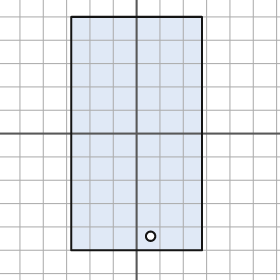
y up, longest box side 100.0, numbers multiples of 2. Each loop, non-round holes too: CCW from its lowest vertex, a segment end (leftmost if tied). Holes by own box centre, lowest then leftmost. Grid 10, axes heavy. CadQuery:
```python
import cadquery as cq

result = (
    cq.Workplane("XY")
    .moveTo(-28.0, -50.0)
    .lineTo(28.0, -50.0)
    .lineTo(28.0, 50.0)
    .lineTo(-28.0, 50.0)
    .close()
    .moveTo(6.0, -44.0)
    .circle(2.0)
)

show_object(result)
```